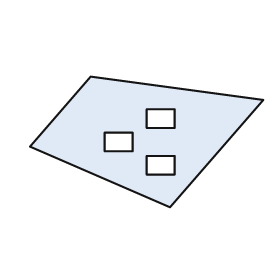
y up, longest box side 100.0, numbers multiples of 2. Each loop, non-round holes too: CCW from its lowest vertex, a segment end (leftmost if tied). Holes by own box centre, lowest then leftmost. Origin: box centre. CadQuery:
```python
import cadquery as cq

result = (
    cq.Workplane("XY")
    .moveTo(10.0, -28.0)
    .lineTo(50.0, 18.0)
    .lineTo(-24.0, 28.0)
    .lineTo(-50.0, -2.0)
    .close()
    .moveTo(0.0, -14.0)
    .lineTo(12.0, -14.0)
    .lineTo(12.0, -6.0)
    .lineTo(0.0, -6.0)
    .close()
    .moveTo(-18.0, -4.0)
    .lineTo(-6.0, -4.0)
    .lineTo(-6.0, 4.0)
    .lineTo(-18.0, 4.0)
    .close()
    .moveTo(0.0, 6.0)
    .lineTo(12.0, 6.0)
    .lineTo(12.0, 14.0)
    .lineTo(0.0, 14.0)
    .close()
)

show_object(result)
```